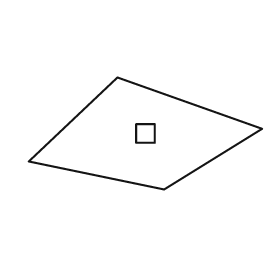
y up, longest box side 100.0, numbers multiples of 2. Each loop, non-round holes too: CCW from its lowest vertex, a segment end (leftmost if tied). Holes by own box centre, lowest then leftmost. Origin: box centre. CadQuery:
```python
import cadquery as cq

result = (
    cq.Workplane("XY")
    .moveTo(8.0, -24.0)
    .lineTo(50.0, 2.0)
    .lineTo(-12.0, 24.0)
    .lineTo(-50.0, -12.0)
    .close()
    .moveTo(-4.0, -4.0)
    .lineTo(4.0, -4.0)
    .lineTo(4.0, 4.0)
    .lineTo(-4.0, 4.0)
    .close()
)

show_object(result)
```